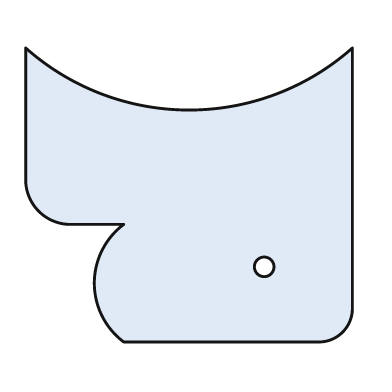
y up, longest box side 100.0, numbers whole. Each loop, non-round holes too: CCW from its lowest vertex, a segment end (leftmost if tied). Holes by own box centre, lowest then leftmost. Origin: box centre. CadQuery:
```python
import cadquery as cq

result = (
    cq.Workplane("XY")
    .moveTo(-20.0, -45.0)
    .lineTo(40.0, -45.0)
    .threePointArc((47.0, -42.0), (50.0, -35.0))
    .lineTo(50.0, 45.0)
    .threePointArc((0.0, 26.0), (-50.0, 45.0))
    .lineTo(-50.0, 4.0)
    .threePointArc((-46.0, -5.0), (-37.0, -9.0))
    .lineTo(-20.0, -9.0)
    .threePointArc((-29.0, -27.0), (-20.0, -45.0))
    .close()
    .moveTo(23.0, -22.0)
    .circle(3.0)
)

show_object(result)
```